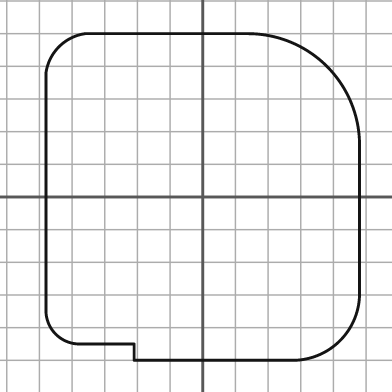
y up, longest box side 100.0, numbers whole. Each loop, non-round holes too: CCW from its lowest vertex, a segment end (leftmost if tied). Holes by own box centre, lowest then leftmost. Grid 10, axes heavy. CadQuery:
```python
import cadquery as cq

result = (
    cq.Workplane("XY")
    .moveTo(-21.0, -50.0)
    .lineTo(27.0, -50.0)
    .threePointArc((42.0, -44.0), (48.0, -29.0))
    .lineTo(48.0, 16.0)
    .threePointArc((38.0, 40.0), (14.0, 50.0))
    .lineTo(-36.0, 50.0)
    .threePointArc((-44.0, 46.0), (-48.0, 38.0))
    .lineTo(-48.0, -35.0)
    .threePointArc((-45.0, -42.0), (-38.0, -45.0))
    .lineTo(-21.0, -45.0)
    .close()
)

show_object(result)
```